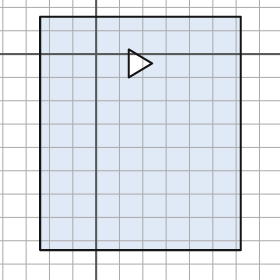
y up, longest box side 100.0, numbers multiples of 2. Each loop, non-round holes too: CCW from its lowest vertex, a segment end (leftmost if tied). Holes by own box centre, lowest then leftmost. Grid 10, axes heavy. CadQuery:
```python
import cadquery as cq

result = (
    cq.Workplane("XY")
    .moveTo(-24.0, -84.0)
    .lineTo(62.0, -84.0)
    .lineTo(62.0, 16.0)
    .lineTo(-24.0, 16.0)
    .close()
    .moveTo(14.0, -10.0)
    .lineTo(24.0, -4.0)
    .lineTo(14.0, 2.0)
    .close()
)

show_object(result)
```